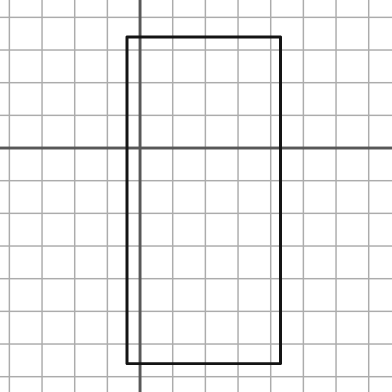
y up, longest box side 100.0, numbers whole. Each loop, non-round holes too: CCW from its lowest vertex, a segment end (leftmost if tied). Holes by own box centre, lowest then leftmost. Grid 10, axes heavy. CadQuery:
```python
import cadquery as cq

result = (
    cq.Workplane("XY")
    .moveTo(-4.0, -66.0)
    .lineTo(43.0, -66.0)
    .lineTo(43.0, 34.0)
    .lineTo(-4.0, 34.0)
    .close()
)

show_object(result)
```